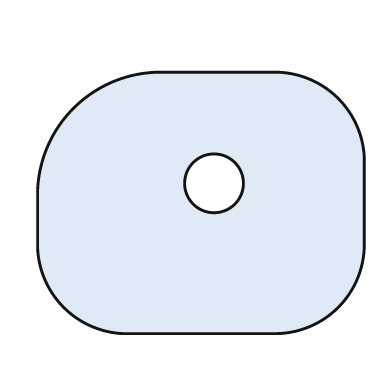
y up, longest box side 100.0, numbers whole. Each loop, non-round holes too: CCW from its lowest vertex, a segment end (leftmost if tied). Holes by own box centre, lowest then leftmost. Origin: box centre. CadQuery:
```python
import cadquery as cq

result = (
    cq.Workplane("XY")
    .moveTo(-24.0, -40.0)
    .lineTo(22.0, -40.0)
    .threePointArc((42.0, -32.0), (50.0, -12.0))
    .lineTo(50.0, 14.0)
    .threePointArc((42.0, 32.0), (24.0, 40.0))
    .lineTo(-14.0, 40.0)
    .threePointArc((-39.0, 29.0), (-50.0, 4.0))
    .lineTo(-50.0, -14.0)
    .threePointArc((-42.0, -32.0), (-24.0, -40.0))
    .close()
    .moveTo(4.0, 6.0)
    .circle(9.0)
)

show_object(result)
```